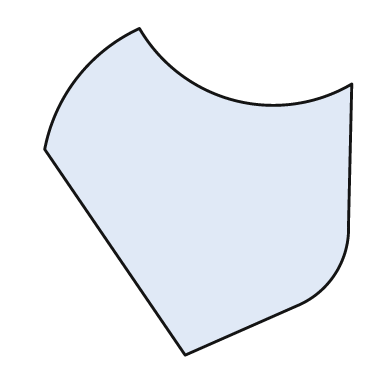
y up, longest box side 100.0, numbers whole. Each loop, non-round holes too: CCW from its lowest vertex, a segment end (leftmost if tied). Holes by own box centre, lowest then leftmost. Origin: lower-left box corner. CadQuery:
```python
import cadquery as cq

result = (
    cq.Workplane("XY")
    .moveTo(43.0, 0.0)
    .lineTo(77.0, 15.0)
    .threePointArc((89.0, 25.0), (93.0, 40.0))
    .lineTo(94.0, 83.0)
    .threePointArc((58.0, 78.0), (29.0, 100.0))
    .threePointArc((10.0, 85.0), (0.0, 63.0))
    .close()
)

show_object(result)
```